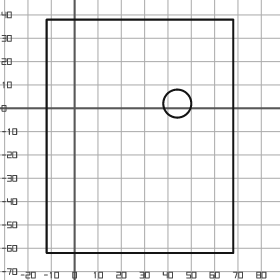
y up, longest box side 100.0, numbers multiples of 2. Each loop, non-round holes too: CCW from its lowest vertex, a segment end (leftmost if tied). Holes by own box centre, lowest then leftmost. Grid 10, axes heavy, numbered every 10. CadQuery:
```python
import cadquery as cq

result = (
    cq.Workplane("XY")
    .moveTo(-12.0, -62.0)
    .lineTo(68.0, -62.0)
    .lineTo(68.0, 38.0)
    .lineTo(-12.0, 38.0)
    .close()
    .moveTo(44.0, 2.0)
    .circle(6.0)
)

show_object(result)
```